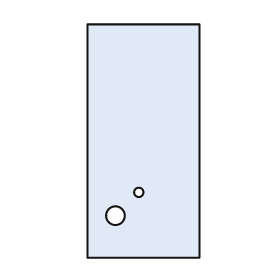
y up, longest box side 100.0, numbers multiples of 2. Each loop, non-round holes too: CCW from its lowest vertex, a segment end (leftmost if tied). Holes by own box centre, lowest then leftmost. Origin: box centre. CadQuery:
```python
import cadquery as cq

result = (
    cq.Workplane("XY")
    .moveTo(-24.0, -50.0)
    .lineTo(24.0, -50.0)
    .lineTo(24.0, 50.0)
    .lineTo(-24.0, 50.0)
    .close()
    .moveTo(-12.0, -32.0)
    .circle(4.0)
    .moveTo(-2.0, -22.0)
    .circle(2.0)
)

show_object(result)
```